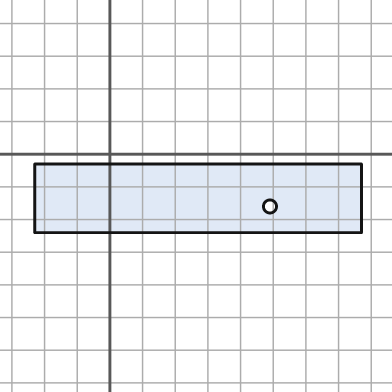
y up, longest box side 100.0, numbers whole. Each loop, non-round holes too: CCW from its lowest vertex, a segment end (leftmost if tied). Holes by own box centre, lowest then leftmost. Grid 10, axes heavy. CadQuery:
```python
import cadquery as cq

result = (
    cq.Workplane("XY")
    .moveTo(-23.0, -24.0)
    .lineTo(77.0, -24.0)
    .lineTo(77.0, -3.0)
    .lineTo(-23.0, -3.0)
    .close()
    .moveTo(49.0, -16.0)
    .circle(2.0)
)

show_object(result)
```